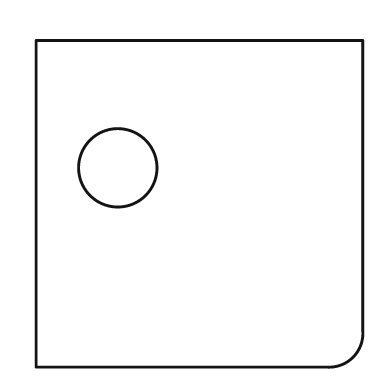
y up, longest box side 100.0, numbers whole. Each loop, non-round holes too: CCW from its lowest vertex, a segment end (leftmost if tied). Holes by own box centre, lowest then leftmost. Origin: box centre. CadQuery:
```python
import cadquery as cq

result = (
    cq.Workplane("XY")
    .moveTo(-50.0, -50.0)
    .lineTo(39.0, -50.0)
    .threePointArc((47.0, -47.0), (50.0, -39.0))
    .lineTo(50.0, 50.0)
    .lineTo(-50.0, 50.0)
    .close()
    .moveTo(-25.0, 11.0)
    .circle(12.0)
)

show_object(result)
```